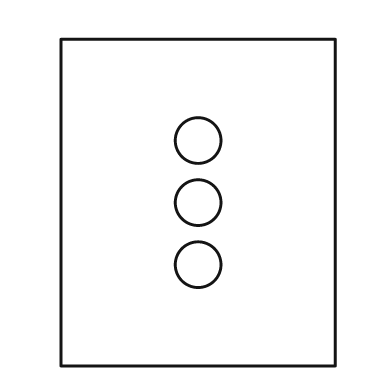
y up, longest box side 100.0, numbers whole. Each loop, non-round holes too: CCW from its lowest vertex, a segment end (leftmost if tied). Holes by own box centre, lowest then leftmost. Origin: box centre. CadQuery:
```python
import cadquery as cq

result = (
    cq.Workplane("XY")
    .moveTo(-42.0, -50.0)
    .lineTo(42.0, -50.0)
    .lineTo(42.0, 50.0)
    .lineTo(-42.0, 50.0)
    .close()
    .moveTo(0.0, -19.0)
    .circle(7.0)
    .moveTo(0.0, 0.0)
    .circle(7.0)
    .moveTo(0.0, 19.0)
    .circle(7.0)
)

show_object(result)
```